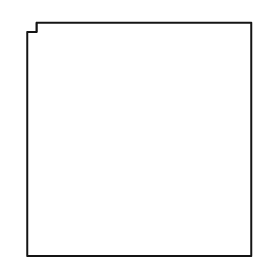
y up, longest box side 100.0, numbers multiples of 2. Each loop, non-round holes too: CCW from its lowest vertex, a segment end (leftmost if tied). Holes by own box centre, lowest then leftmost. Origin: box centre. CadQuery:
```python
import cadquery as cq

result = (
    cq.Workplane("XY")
    .moveTo(-48.0, -50.0)
    .lineTo(48.0, -50.0)
    .lineTo(48.0, 50.0)
    .lineTo(-44.0, 50.0)
    .lineTo(-44.0, 46.0)
    .lineTo(-48.0, 46.0)
    .close()
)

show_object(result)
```